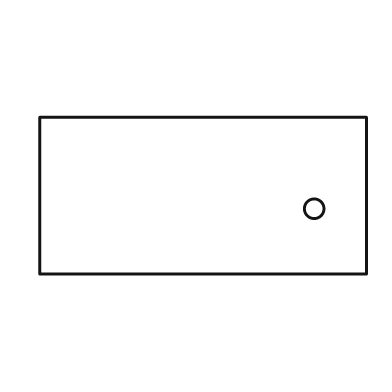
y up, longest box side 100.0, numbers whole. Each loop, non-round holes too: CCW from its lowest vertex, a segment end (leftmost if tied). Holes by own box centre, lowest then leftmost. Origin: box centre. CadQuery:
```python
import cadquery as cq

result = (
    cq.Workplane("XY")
    .moveTo(-50.0, -24.0)
    .lineTo(50.0, -24.0)
    .lineTo(50.0, 24.0)
    .lineTo(-50.0, 24.0)
    .close()
    .moveTo(34.0, -4.0)
    .circle(3.0)
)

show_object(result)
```